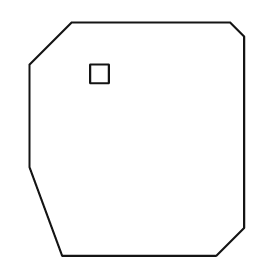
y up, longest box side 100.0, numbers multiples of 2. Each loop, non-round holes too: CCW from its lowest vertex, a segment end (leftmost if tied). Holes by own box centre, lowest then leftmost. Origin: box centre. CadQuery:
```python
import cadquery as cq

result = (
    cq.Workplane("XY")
    .moveTo(-32.0, -50.0)
    .lineTo(34.0, -50.0)
    .lineTo(46.0, -38.0)
    .lineTo(46.0, 44.0)
    .lineTo(40.0, 50.0)
    .lineTo(-28.0, 50.0)
    .lineTo(-46.0, 32.0)
    .lineTo(-46.0, -12.0)
    .close()
    .moveTo(-20.0, 24.0)
    .lineTo(-12.0, 24.0)
    .lineTo(-12.0, 32.0)
    .lineTo(-20.0, 32.0)
    .close()
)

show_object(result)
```